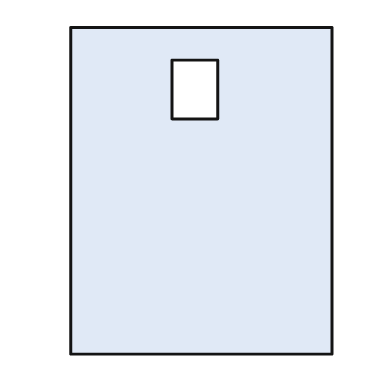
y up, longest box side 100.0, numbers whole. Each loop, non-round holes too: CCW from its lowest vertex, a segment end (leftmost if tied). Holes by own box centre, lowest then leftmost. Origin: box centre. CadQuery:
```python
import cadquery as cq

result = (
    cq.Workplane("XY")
    .moveTo(-40.0, -50.0)
    .lineTo(40.0, -50.0)
    .lineTo(40.0, 50.0)
    .lineTo(-40.0, 50.0)
    .close()
    .moveTo(-9.0, 22.0)
    .lineTo(5.0, 22.0)
    .lineTo(5.0, 40.0)
    .lineTo(-9.0, 40.0)
    .close()
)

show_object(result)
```